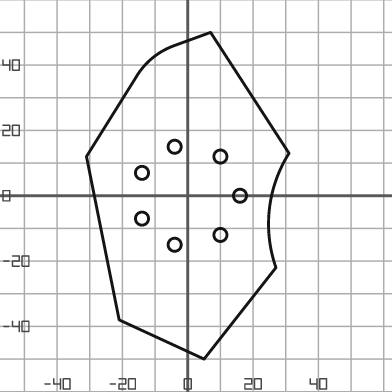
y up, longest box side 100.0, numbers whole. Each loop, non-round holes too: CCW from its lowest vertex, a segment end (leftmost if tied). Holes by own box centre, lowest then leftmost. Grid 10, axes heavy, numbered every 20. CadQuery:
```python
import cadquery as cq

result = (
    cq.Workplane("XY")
    .moveTo(5.0, -50.0)
    .lineTo(27.0, -22.0)
    .threePointArc((25.0, -4.0), (31.0, 13.0))
    .lineTo(7.0, 50.0)
    .lineTo(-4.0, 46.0)
    .threePointArc((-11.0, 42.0), (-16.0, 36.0))
    .lineTo(-31.0, 12.0)
    .lineTo(-21.0, -38.0)
    .close()
    .moveTo(-4.0, -15.0)
    .circle(2.0)
    .moveTo(10.0, -12.0)
    .circle(2.0)
    .moveTo(-14.0, -7.0)
    .circle(2.0)
    .moveTo(16.0, 0.0)
    .circle(2.0)
    .moveTo(-14.0, 7.0)
    .circle(2.0)
    .moveTo(10.0, 12.0)
    .circle(2.0)
    .moveTo(-4.0, 15.0)
    .circle(2.0)
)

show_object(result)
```